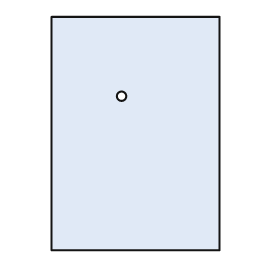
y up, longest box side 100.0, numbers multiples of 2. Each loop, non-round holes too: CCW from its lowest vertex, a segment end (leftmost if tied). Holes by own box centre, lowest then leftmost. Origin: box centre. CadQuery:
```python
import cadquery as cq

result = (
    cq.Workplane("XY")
    .moveTo(-36.0, -50.0)
    .lineTo(36.0, -50.0)
    .lineTo(36.0, 50.0)
    .lineTo(-36.0, 50.0)
    .close()
    .moveTo(-6.0, 16.0)
    .circle(2.0)
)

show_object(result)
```